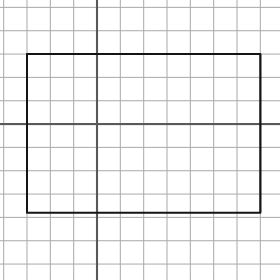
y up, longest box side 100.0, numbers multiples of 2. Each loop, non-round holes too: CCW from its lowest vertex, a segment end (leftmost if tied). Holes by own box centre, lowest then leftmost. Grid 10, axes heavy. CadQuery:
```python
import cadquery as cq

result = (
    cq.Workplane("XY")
    .moveTo(-30.0, -38.0)
    .lineTo(70.0, -38.0)
    .lineTo(70.0, 30.0)
    .lineTo(-30.0, 30.0)
    .close()
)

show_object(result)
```